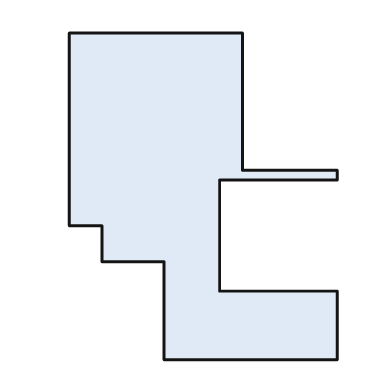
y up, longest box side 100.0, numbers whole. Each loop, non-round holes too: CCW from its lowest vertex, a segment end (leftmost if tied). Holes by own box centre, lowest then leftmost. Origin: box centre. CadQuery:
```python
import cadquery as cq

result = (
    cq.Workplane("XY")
    .moveTo(-12.0, -50.0)
    .lineTo(41.0, -50.0)
    .lineTo(41.0, -29.0)
    .lineTo(5.0, -29.0)
    .lineTo(5.0, 5.0)
    .lineTo(41.0, 5.0)
    .lineTo(41.0, 8.0)
    .lineTo(12.0, 8.0)
    .lineTo(12.0, 50.0)
    .lineTo(-41.0, 50.0)
    .lineTo(-41.0, -9.0)
    .lineTo(-31.0, -9.0)
    .lineTo(-31.0, -20.0)
    .lineTo(-12.0, -20.0)
    .close()
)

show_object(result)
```